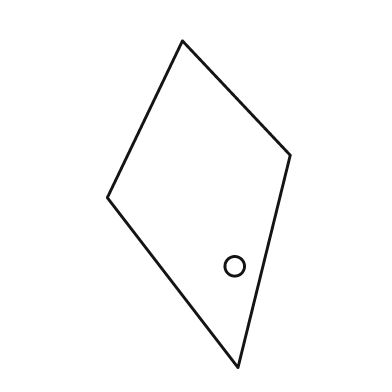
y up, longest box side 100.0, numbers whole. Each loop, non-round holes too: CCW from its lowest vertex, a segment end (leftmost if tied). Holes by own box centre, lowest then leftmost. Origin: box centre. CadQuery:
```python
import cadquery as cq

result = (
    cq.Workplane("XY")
    .moveTo(12.0, -50.0)
    .lineTo(28.0, 15.0)
    .lineTo(-5.0, 50.0)
    .lineTo(-28.0, 2.0)
    .close()
    .moveTo(11.0, -19.0)
    .circle(3.0)
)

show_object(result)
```